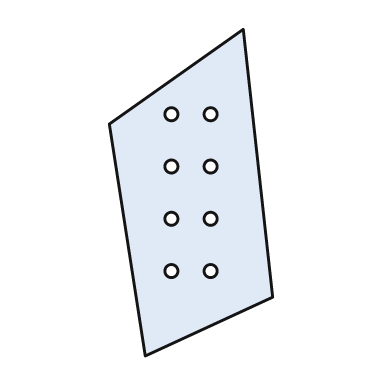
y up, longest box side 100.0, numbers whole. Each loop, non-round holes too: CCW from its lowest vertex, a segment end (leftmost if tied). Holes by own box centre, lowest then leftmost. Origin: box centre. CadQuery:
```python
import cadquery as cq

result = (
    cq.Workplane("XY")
    .moveTo(-14.0, -50.0)
    .lineTo(25.0, -32.0)
    .lineTo(16.0, 50.0)
    .lineTo(-25.0, 21.0)
    .close()
    .moveTo(-6.0, -24.0)
    .circle(2.0)
    .moveTo(6.0, -24.0)
    .circle(2.0)
    .moveTo(-6.0, -8.0)
    .circle(2.0)
    .moveTo(6.0, -8.0)
    .circle(2.0)
    .moveTo(-6.0, 8.0)
    .circle(2.0)
    .moveTo(6.0, 8.0)
    .circle(2.0)
    .moveTo(-6.0, 24.0)
    .circle(2.0)
    .moveTo(6.0, 24.0)
    .circle(2.0)
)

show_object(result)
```